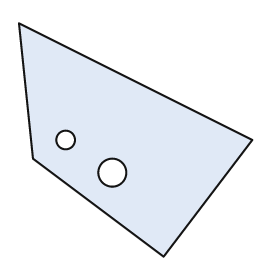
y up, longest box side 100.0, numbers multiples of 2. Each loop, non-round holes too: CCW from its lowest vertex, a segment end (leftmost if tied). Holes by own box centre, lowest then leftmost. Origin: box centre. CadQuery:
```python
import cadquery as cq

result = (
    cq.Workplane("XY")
    .moveTo(12.0, -50.0)
    .lineTo(50.0, 0.0)
    .lineTo(-50.0, 50.0)
    .lineTo(-44.0, -8.0)
    .close()
    .moveTo(-10.0, -14.0)
    .circle(6.0)
    .moveTo(-30.0, 0.0)
    .circle(4.0)
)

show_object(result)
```